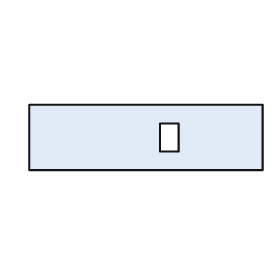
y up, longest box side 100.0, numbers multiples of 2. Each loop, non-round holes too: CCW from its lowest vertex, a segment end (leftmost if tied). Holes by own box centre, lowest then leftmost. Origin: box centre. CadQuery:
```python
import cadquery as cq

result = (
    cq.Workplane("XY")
    .moveTo(-50.0, -14.0)
    .lineTo(50.0, -14.0)
    .lineTo(50.0, 14.0)
    .lineTo(-50.0, 14.0)
    .close()
    .moveTo(6.0, -6.0)
    .lineTo(14.0, -6.0)
    .lineTo(14.0, 6.0)
    .lineTo(6.0, 6.0)
    .close()
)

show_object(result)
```